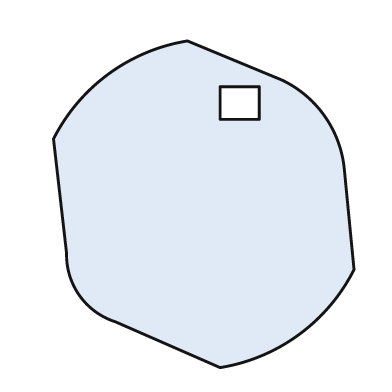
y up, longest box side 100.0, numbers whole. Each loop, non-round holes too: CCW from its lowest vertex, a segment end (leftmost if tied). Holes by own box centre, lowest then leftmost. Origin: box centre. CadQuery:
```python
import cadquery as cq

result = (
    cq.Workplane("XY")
    .moveTo(5.0, -50.0)
    .threePointArc((29.0, -40.0), (46.0, -20.0))
    .lineTo(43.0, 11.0)
    .threePointArc((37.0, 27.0), (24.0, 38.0))
    .lineTo(-5.0, 50.0)
    .threePointArc((-29.0, 40.0), (-46.0, 20.0))
    .lineTo(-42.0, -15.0)
    .threePointArc((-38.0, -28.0), (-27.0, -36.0))
    .close()
    .moveTo(5.0, 26.0)
    .lineTo(17.0, 26.0)
    .lineTo(17.0, 36.0)
    .lineTo(5.0, 36.0)
    .close()
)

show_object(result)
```